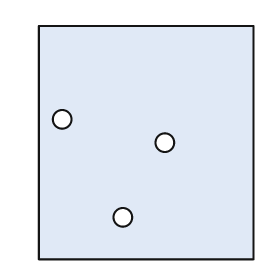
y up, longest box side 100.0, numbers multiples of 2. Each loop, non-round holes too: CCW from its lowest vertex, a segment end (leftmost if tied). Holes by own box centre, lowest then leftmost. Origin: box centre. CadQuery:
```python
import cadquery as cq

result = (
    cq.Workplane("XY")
    .moveTo(-46.0, -50.0)
    .lineTo(46.0, -50.0)
    .lineTo(46.0, 50.0)
    .lineTo(-46.0, 50.0)
    .close()
    .moveTo(-10.0, -32.0)
    .circle(4.0)
    .moveTo(8.0, 0.0)
    .circle(4.0)
    .moveTo(-36.0, 10.0)
    .circle(4.0)
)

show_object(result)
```